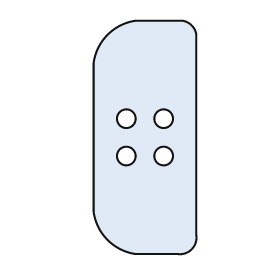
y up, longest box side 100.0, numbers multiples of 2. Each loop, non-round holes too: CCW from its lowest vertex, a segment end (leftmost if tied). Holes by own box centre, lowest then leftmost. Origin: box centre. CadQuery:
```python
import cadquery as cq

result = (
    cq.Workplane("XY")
    .moveTo(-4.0, -50.0)
    .lineTo(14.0, -50.0)
    .threePointArc((20.0, -48.0), (22.0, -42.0))
    .lineTo(22.0, 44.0)
    .threePointArc((20.0, 48.0), (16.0, 50.0))
    .lineTo(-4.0, 50.0)
    .threePointArc((-16.0, 44.0), (-22.0, 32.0))
    .lineTo(-22.0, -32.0)
    .threePointArc((-16.0, -44.0), (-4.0, -50.0))
    .close()
    .moveTo(-8.0, -8.0)
    .circle(4.0)
    .moveTo(8.0, -8.0)
    .circle(4.0)
    .moveTo(-8.0, 8.0)
    .circle(4.0)
    .moveTo(8.0, 8.0)
    .circle(4.0)
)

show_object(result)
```